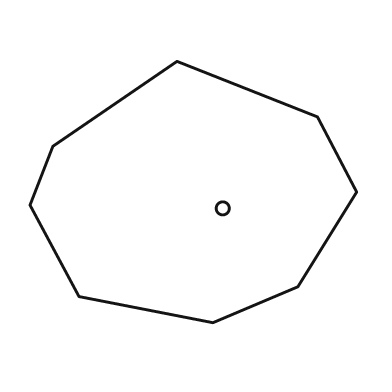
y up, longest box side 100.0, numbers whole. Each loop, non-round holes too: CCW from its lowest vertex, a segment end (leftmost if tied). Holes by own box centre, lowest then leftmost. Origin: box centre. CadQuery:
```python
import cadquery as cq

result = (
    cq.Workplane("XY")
    .moveTo(6.0, -40.0)
    .lineTo(32.0, -29.0)
    .lineTo(50.0, 0.0)
    .lineTo(38.0, 23.0)
    .lineTo(-5.0, 40.0)
    .lineTo(-43.0, 14.0)
    .lineTo(-50.0, -4.0)
    .lineTo(-35.0, -32.0)
    .close()
    .moveTo(9.0, -5.0)
    .circle(2.0)
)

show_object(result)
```